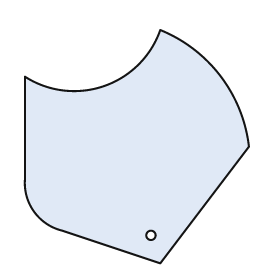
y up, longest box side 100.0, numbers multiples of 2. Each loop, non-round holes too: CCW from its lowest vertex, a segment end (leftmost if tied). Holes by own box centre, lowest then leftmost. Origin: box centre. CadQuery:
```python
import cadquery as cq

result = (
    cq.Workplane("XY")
    .moveTo(10.0, -50.0)
    .lineTo(48.0, 0.0)
    .threePointArc((36.0, 30.0), (10.0, 50.0))
    .threePointArc((-14.0, 26.0), (-48.0, 30.0))
    .lineTo(-48.0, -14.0)
    .threePointArc((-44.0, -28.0), (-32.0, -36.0))
    .close()
    .moveTo(6.0, -38.0)
    .circle(2.0)
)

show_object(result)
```